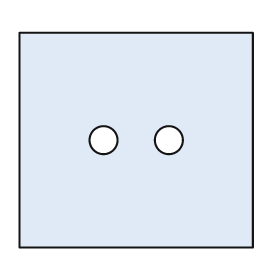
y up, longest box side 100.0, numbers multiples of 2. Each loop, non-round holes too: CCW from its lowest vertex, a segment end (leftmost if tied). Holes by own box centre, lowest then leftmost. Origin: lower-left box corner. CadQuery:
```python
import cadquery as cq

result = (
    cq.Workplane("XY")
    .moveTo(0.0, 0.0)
    .lineTo(100.0, 0.0)
    .lineTo(100.0, 92.0)
    .lineTo(0.0, 92.0)
    .close()
    .moveTo(36.0, 46.0)
    .circle(6.0)
    .moveTo(64.0, 46.0)
    .circle(6.0)
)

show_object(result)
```